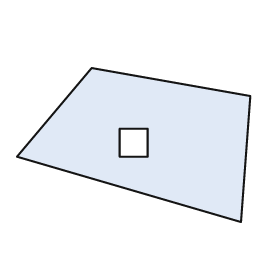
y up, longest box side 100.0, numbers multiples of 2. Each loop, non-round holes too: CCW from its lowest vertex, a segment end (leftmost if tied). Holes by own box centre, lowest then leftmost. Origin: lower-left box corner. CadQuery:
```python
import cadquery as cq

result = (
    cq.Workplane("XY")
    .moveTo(96.0, 0.0)
    .lineTo(100.0, 54.0)
    .lineTo(32.0, 66.0)
    .lineTo(0.0, 28.0)
    .close()
    .moveTo(44.0, 28.0)
    .lineTo(56.0, 28.0)
    .lineTo(56.0, 40.0)
    .lineTo(44.0, 40.0)
    .close()
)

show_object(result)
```